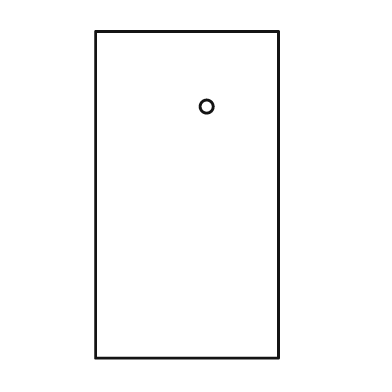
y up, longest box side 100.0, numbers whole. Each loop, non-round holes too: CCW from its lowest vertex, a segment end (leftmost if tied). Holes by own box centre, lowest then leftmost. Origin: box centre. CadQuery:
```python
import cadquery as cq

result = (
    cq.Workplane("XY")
    .moveTo(-28.0, -50.0)
    .lineTo(28.0, -50.0)
    .lineTo(28.0, 50.0)
    .lineTo(-28.0, 50.0)
    .close()
    .moveTo(6.0, 27.0)
    .circle(2.0)
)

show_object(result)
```